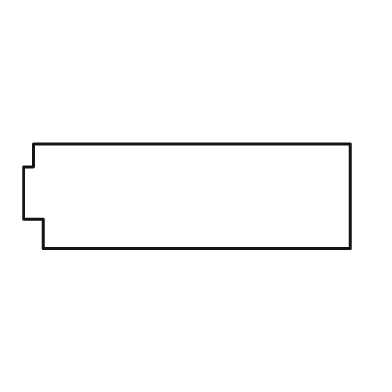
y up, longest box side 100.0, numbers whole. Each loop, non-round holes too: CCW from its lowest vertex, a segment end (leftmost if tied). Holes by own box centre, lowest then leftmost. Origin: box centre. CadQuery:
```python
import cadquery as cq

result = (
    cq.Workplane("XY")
    .moveTo(-44.0, -16.0)
    .lineTo(50.0, -16.0)
    .lineTo(50.0, 16.0)
    .lineTo(-47.0, 16.0)
    .lineTo(-47.0, 9.0)
    .lineTo(-50.0, 9.0)
    .lineTo(-50.0, -7.0)
    .lineTo(-44.0, -7.0)
    .close()
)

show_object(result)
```